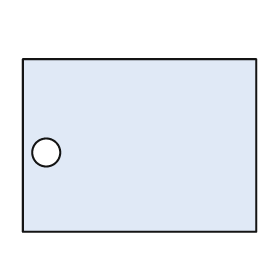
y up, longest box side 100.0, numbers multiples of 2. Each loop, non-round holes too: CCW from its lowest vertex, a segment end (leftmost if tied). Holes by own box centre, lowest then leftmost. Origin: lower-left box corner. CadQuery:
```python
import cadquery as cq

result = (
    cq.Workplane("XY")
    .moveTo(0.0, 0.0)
    .lineTo(100.0, 0.0)
    .lineTo(100.0, 74.0)
    .lineTo(0.0, 74.0)
    .close()
    .moveTo(10.0, 34.0)
    .circle(6.0)
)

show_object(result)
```